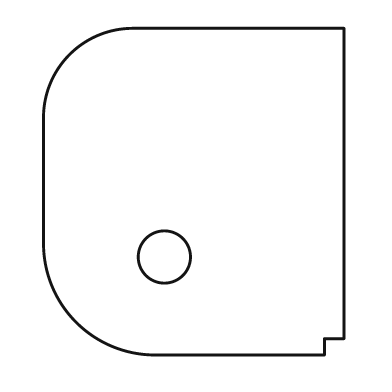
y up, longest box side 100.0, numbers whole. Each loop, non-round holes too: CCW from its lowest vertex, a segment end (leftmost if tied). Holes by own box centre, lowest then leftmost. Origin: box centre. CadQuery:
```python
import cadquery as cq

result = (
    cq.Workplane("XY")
    .moveTo(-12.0, -50.0)
    .lineTo(40.0, -50.0)
    .lineTo(40.0, -45.0)
    .lineTo(46.0, -45.0)
    .lineTo(46.0, 50.0)
    .lineTo(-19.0, 50.0)
    .threePointArc((-38.0, 42.0), (-46.0, 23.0))
    .lineTo(-46.0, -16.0)
    .threePointArc((-36.0, -40.0), (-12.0, -50.0))
    .close()
    .moveTo(-9.0, -20.0)
    .circle(8.0)
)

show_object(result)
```